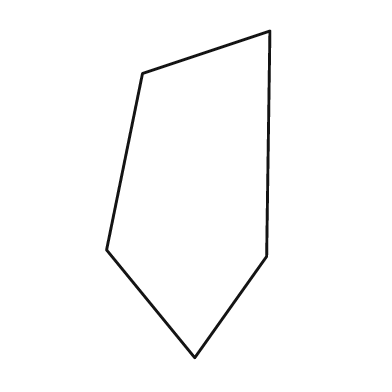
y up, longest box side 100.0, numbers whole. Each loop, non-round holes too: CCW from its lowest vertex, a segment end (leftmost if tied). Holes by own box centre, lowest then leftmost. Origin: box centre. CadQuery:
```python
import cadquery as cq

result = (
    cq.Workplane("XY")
    .moveTo(2.0, -50.0)
    .lineTo(24.0, -19.0)
    .lineTo(25.0, 50.0)
    .lineTo(-14.0, 37.0)
    .lineTo(-25.0, -17.0)
    .close()
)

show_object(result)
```